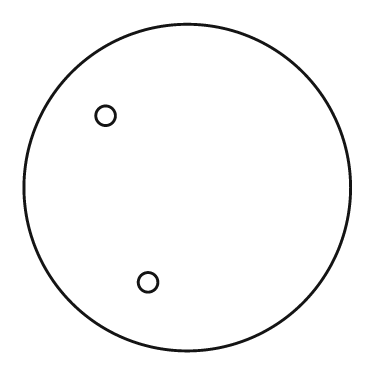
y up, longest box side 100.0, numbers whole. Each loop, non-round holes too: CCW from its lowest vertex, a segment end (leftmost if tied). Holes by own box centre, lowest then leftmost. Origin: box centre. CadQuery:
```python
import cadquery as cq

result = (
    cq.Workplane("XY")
    .moveTo(0.0, 0.0)
    .circle(50.0)
    .moveTo(-12.0, -29.0)
    .circle(3.0)
    .moveTo(-25.0, 22.0)
    .circle(3.0)
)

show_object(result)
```